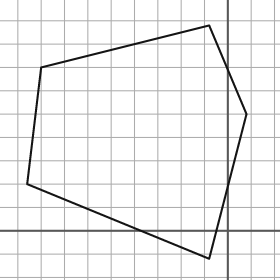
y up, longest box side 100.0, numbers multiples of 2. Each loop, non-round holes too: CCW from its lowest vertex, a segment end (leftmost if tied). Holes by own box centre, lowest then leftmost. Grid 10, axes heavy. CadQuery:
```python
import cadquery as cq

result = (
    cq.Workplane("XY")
    .moveTo(-8.0, -12.0)
    .lineTo(8.0, 50.0)
    .lineTo(-8.0, 88.0)
    .lineTo(-80.0, 70.0)
    .lineTo(-86.0, 20.0)
    .close()
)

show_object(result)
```